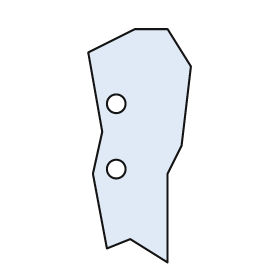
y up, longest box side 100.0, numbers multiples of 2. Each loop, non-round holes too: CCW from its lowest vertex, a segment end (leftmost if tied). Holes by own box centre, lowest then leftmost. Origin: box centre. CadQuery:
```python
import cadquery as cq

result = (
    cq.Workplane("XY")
    .moveTo(12.0, -50.0)
    .lineTo(12.0, -12.0)
    .lineTo(18.0, 0.0)
    .lineTo(22.0, 34.0)
    .lineTo(12.0, 50.0)
    .lineTo(-2.0, 50.0)
    .lineTo(-22.0, 40.0)
    .lineTo(-16.0, 6.0)
    .lineTo(-20.0, -12.0)
    .lineTo(-14.0, -44.0)
    .lineTo(-4.0, -40.0)
    .close()
    .moveTo(-10.0, -10.0)
    .circle(4.0)
    .moveTo(-10.0, 18.0)
    .circle(4.0)
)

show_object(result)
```